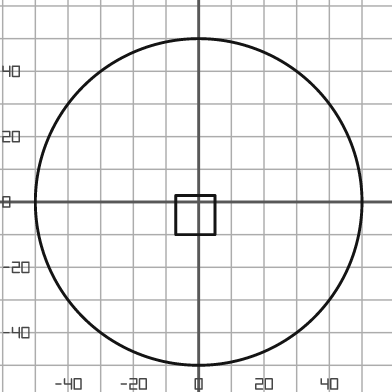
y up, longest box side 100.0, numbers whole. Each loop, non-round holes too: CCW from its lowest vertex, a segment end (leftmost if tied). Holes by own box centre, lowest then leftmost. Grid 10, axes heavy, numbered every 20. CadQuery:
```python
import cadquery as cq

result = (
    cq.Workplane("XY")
    .moveTo(0.0, 0.0)
    .circle(50.0)
    .moveTo(-7.0, -10.0)
    .lineTo(5.0, -10.0)
    .lineTo(5.0, 2.0)
    .lineTo(-7.0, 2.0)
    .close()
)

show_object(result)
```